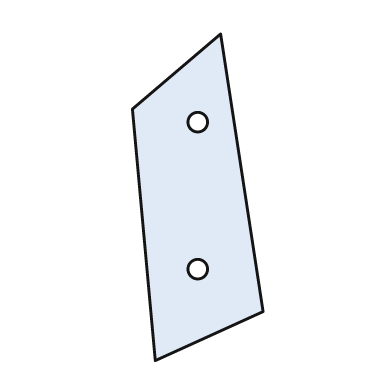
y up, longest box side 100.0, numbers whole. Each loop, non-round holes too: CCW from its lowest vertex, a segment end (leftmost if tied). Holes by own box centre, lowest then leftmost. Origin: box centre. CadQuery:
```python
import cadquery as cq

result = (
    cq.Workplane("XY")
    .moveTo(-13.0, -50.0)
    .lineTo(20.0, -35.0)
    .lineTo(7.0, 50.0)
    .lineTo(-20.0, 27.0)
    .close()
    .moveTo(0.0, -22.0)
    .circle(3.0)
    .moveTo(0.0, 23.0)
    .circle(3.0)
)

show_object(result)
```